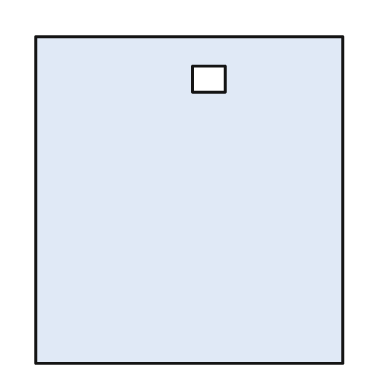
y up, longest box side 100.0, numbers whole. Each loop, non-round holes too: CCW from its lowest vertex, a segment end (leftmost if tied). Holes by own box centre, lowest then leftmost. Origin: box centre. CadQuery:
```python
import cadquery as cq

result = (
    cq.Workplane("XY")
    .moveTo(-47.0, -50.0)
    .lineTo(47.0, -50.0)
    .lineTo(47.0, 50.0)
    .lineTo(-47.0, 50.0)
    .close()
    .moveTo(1.0, 33.0)
    .lineTo(11.0, 33.0)
    .lineTo(11.0, 41.0)
    .lineTo(1.0, 41.0)
    .close()
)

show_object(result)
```